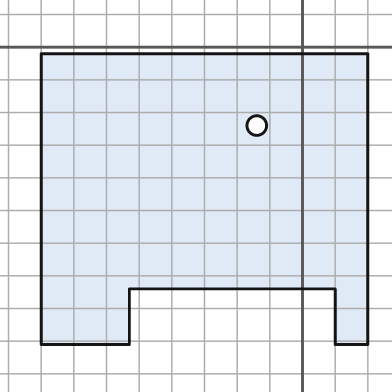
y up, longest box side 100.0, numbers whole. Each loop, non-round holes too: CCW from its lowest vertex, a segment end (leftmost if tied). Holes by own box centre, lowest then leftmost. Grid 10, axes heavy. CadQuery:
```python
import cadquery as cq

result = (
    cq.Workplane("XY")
    .moveTo(-80.0, -91.0)
    .lineTo(-53.0, -91.0)
    .lineTo(-53.0, -74.0)
    .lineTo(10.0, -74.0)
    .lineTo(10.0, -91.0)
    .lineTo(20.0, -91.0)
    .lineTo(20.0, -2.0)
    .lineTo(-80.0, -2.0)
    .close()
    .moveTo(-14.0, -24.0)
    .circle(3.0)
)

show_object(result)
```